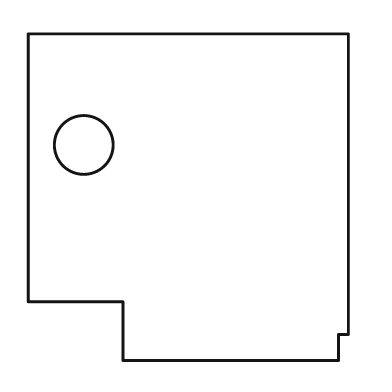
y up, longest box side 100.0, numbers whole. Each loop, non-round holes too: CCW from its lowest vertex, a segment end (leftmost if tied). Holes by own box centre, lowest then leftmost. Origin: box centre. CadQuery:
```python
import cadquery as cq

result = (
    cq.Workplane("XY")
    .moveTo(-20.0, -50.0)
    .lineTo(46.0, -50.0)
    .lineTo(46.0, -42.0)
    .lineTo(49.0, -42.0)
    .lineTo(49.0, 50.0)
    .lineTo(-49.0, 50.0)
    .lineTo(-49.0, -32.0)
    .lineTo(-20.0, -32.0)
    .close()
    .moveTo(-32.0, 16.0)
    .circle(9.0)
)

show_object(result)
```